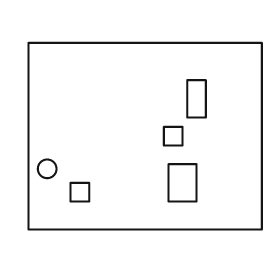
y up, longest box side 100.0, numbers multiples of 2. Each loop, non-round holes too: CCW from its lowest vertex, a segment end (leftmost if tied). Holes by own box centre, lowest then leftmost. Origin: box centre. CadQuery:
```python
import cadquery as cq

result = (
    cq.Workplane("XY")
    .moveTo(-50.0, -40.0)
    .lineTo(50.0, -40.0)
    .lineTo(50.0, 40.0)
    .lineTo(-50.0, 40.0)
    .close()
    .moveTo(-32.0, -28.0)
    .lineTo(-24.0, -28.0)
    .lineTo(-24.0, -20.0)
    .lineTo(-32.0, -20.0)
    .close()
    .moveTo(10.0, -28.0)
    .lineTo(22.0, -28.0)
    .lineTo(22.0, -12.0)
    .lineTo(10.0, -12.0)
    .close()
    .moveTo(-42.0, -14.0)
    .circle(4.0)
    .moveTo(8.0, -4.0)
    .lineTo(16.0, -4.0)
    .lineTo(16.0, 4.0)
    .lineTo(8.0, 4.0)
    .close()
    .moveTo(18.0, 8.0)
    .lineTo(26.0, 8.0)
    .lineTo(26.0, 24.0)
    .lineTo(18.0, 24.0)
    .close()
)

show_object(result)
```